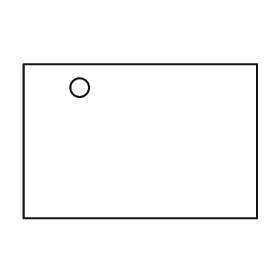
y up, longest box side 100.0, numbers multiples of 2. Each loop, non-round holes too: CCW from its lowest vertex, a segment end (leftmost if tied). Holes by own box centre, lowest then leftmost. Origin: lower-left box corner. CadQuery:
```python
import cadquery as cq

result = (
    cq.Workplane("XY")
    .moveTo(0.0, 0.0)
    .lineTo(100.0, 0.0)
    .lineTo(100.0, 66.0)
    .lineTo(0.0, 66.0)
    .close()
    .moveTo(24.0, 56.0)
    .circle(4.0)
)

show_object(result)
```